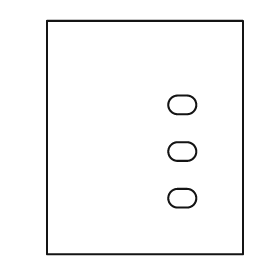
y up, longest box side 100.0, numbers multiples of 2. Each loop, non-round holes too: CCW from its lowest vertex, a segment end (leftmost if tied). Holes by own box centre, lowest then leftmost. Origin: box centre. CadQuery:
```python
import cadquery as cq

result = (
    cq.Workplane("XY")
    .moveTo(-42.0, -50.0)
    .lineTo(42.0, -50.0)
    .lineTo(42.0, 50.0)
    .lineTo(-42.0, 50.0)
    .close()
    .moveTo(14.0, -30.0)
    .lineTo(18.0, -30.0)
    .threePointArc((22.0, -26.0), (18.0, -22.0))
    .lineTo(14.0, -22.0)
    .threePointArc((10.0, -26.0), (14.0, -30.0))
    .close()
    .moveTo(14.0, -10.0)
    .lineTo(18.0, -10.0)
    .threePointArc((22.0, -6.0), (18.0, -2.0))
    .lineTo(14.0, -2.0)
    .threePointArc((10.0, -6.0), (14.0, -10.0))
    .close()
    .moveTo(14.0, 10.0)
    .lineTo(18.0, 10.0)
    .threePointArc((22.0, 14.0), (18.0, 18.0))
    .lineTo(14.0, 18.0)
    .threePointArc((10.0, 14.0), (14.0, 10.0))
    .close()
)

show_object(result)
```